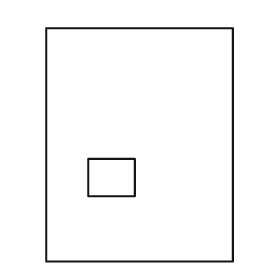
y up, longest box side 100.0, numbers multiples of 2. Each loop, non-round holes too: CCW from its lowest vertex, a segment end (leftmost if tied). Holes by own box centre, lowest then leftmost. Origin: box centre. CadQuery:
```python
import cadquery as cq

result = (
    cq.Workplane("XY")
    .moveTo(-40.0, -50.0)
    .lineTo(40.0, -50.0)
    .lineTo(40.0, 50.0)
    .lineTo(-40.0, 50.0)
    .close()
    .moveTo(-22.0, -22.0)
    .lineTo(-2.0, -22.0)
    .lineTo(-2.0, -6.0)
    .lineTo(-22.0, -6.0)
    .close()
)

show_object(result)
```